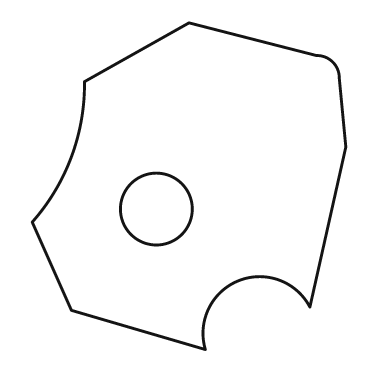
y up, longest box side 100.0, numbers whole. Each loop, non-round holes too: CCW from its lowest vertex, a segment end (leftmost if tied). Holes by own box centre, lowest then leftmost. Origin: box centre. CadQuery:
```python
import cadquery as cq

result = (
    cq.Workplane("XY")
    .moveTo(5.0, -50.0)
    .threePointArc((15.0, -29.0), (37.0, -37.0))
    .lineTo(48.0, 12.0)
    .lineTo(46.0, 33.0)
    .threePointArc((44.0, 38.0), (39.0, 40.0))
    .lineTo(0.0, 50.0)
    .lineTo(-32.0, 32.0)
    .threePointArc((-36.0, 9.0), (-48.0, -11.0))
    .lineTo(-36.0, -38.0)
    .close()
    .moveTo(-10.0, -7.0)
    .circle(11.0)
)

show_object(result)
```